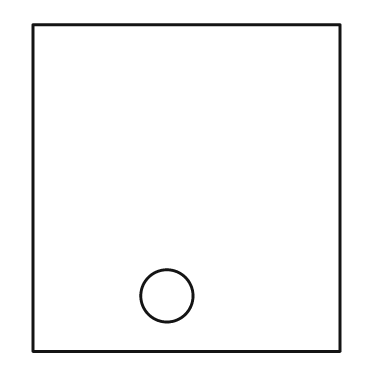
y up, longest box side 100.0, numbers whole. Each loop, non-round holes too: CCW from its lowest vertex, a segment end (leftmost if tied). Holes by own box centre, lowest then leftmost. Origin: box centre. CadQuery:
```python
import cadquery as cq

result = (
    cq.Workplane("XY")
    .moveTo(-47.0, -50.0)
    .lineTo(47.0, -50.0)
    .lineTo(47.0, 50.0)
    .lineTo(-47.0, 50.0)
    .close()
    .moveTo(-6.0, -33.0)
    .circle(8.0)
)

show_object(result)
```